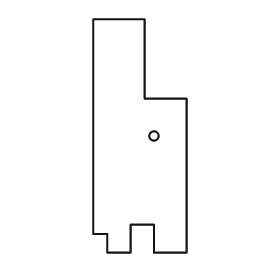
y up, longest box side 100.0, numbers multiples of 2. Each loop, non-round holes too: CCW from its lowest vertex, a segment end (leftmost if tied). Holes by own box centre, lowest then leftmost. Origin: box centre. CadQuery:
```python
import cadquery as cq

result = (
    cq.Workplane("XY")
    .moveTo(-14.0, -50.0)
    .lineTo(-4.0, -50.0)
    .lineTo(-4.0, -38.0)
    .lineTo(6.0, -38.0)
    .lineTo(6.0, -50.0)
    .lineTo(20.0, -50.0)
    .lineTo(20.0, 16.0)
    .lineTo(2.0, 16.0)
    .lineTo(2.0, 50.0)
    .lineTo(-20.0, 50.0)
    .lineTo(-20.0, -42.0)
    .lineTo(-14.0, -42.0)
    .close()
    .moveTo(6.0, 0.0)
    .circle(2.0)
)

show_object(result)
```